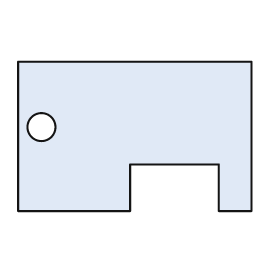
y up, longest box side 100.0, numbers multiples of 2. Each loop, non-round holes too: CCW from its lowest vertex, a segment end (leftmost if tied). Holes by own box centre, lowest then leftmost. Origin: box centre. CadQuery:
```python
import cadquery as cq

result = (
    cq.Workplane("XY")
    .moveTo(-50.0, -32.0)
    .lineTo(-2.0, -32.0)
    .lineTo(-2.0, -12.0)
    .lineTo(36.0, -12.0)
    .lineTo(36.0, -32.0)
    .lineTo(50.0, -32.0)
    .lineTo(50.0, 32.0)
    .lineTo(-50.0, 32.0)
    .close()
    .moveTo(-40.0, 4.0)
    .circle(6.0)
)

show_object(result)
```